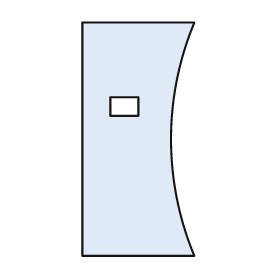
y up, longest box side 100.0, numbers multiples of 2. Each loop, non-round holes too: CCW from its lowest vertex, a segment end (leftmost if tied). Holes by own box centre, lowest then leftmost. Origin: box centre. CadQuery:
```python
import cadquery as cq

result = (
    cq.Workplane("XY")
    .moveTo(-24.0, -50.0)
    .lineTo(24.0, -50.0)
    .threePointArc((14.0, 0.0), (24.0, 50.0))
    .lineTo(-24.0, 50.0)
    .close()
    .moveTo(-12.0, 10.0)
    .lineTo(0.0, 10.0)
    .lineTo(0.0, 18.0)
    .lineTo(-12.0, 18.0)
    .close()
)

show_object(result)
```